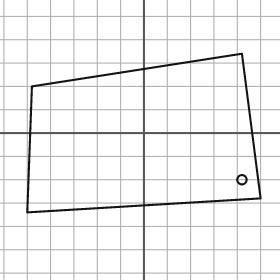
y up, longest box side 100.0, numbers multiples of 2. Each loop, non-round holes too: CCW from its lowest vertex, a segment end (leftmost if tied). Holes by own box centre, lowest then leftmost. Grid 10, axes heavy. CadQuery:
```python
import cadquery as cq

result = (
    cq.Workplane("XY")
    .moveTo(-50.0, -34.0)
    .lineTo(50.0, -28.0)
    .lineTo(42.0, 34.0)
    .lineTo(-48.0, 20.0)
    .close()
    .moveTo(42.0, -20.0)
    .circle(2.0)
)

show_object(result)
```